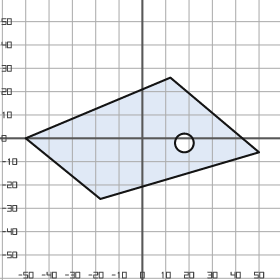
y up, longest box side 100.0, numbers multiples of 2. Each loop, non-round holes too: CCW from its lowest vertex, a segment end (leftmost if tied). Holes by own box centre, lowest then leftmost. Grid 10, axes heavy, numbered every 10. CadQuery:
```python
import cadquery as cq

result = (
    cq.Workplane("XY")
    .moveTo(-18.0, -26.0)
    .lineTo(50.0, -6.0)
    .lineTo(12.0, 26.0)
    .lineTo(-50.0, 0.0)
    .close()
    .moveTo(18.0, -2.0)
    .circle(4.0)
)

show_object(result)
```